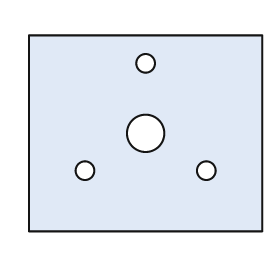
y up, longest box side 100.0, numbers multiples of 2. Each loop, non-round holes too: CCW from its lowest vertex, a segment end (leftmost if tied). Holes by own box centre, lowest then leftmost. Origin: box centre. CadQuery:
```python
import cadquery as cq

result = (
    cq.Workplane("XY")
    .moveTo(-50.0, -42.0)
    .lineTo(50.0, -42.0)
    .lineTo(50.0, 42.0)
    .lineTo(-50.0, 42.0)
    .close()
    .moveTo(-26.0, -16.0)
    .circle(4.0)
    .moveTo(26.0, -16.0)
    .circle(4.0)
    .moveTo(0.0, 0.0)
    .circle(8.0)
    .moveTo(0.0, 30.0)
    .circle(4.0)
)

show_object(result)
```